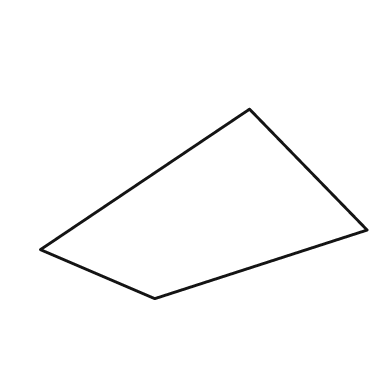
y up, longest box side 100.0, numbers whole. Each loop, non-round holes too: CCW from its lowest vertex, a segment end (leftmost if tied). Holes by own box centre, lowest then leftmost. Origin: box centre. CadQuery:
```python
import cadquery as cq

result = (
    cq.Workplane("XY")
    .moveTo(-15.0, -29.0)
    .lineTo(50.0, -8.0)
    .lineTo(14.0, 29.0)
    .lineTo(-50.0, -14.0)
    .close()
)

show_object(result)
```